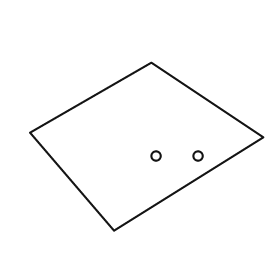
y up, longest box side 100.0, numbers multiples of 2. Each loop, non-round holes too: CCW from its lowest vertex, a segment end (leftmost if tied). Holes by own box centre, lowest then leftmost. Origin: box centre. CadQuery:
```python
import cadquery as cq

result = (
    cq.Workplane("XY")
    .moveTo(-14.0, -36.0)
    .lineTo(50.0, 4.0)
    .lineTo(2.0, 36.0)
    .lineTo(-50.0, 6.0)
    .close()
    .moveTo(4.0, -4.0)
    .circle(2.0)
    .moveTo(22.0, -4.0)
    .circle(2.0)
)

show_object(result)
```